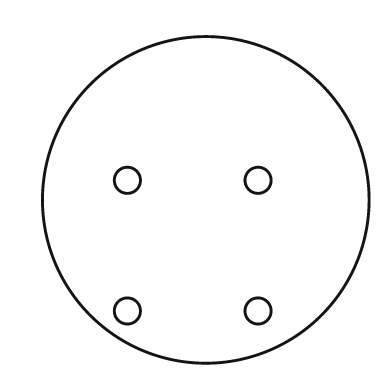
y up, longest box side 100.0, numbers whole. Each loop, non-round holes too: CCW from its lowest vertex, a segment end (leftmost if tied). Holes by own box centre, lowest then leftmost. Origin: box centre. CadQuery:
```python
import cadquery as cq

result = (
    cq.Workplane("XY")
    .moveTo(0.0, 0.0)
    .circle(50.0)
    .moveTo(-24.0, -34.0)
    .circle(4.0)
    .moveTo(16.0, -34.0)
    .circle(4.0)
    .moveTo(-24.0, 6.0)
    .circle(4.0)
    .moveTo(16.0, 6.0)
    .circle(4.0)
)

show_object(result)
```